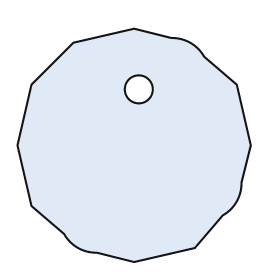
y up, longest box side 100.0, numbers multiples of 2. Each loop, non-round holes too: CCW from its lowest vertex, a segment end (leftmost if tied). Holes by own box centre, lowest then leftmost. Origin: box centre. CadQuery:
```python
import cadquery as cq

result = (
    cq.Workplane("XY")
    .moveTo(0.0, -50.0)
    .lineTo(26.0, -44.0)
    .lineTo(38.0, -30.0)
    .threePointArc((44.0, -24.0), (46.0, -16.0))
    .lineTo(50.0, 0.0)
    .lineTo(44.0, 26.0)
    .lineTo(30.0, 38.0)
    .threePointArc((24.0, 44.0), (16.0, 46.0))
    .lineTo(0.0, 50.0)
    .lineTo(-26.0, 44.0)
    .lineTo(-44.0, 26.0)
    .lineTo(-50.0, 0.0)
    .lineTo(-44.0, -26.0)
    .lineTo(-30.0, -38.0)
    .threePointArc((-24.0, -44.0), (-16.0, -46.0))
    .close()
    .moveTo(2.0, 24.0)
    .circle(6.0)
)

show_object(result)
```